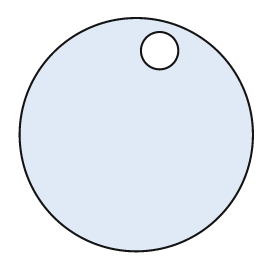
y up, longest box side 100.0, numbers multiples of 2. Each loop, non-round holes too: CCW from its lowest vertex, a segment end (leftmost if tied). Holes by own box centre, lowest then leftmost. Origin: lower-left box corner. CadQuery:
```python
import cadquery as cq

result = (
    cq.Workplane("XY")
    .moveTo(50.0, 50.0)
    .circle(50.0)
    .moveTo(60.0, 86.0)
    .circle(8.0)
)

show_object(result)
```